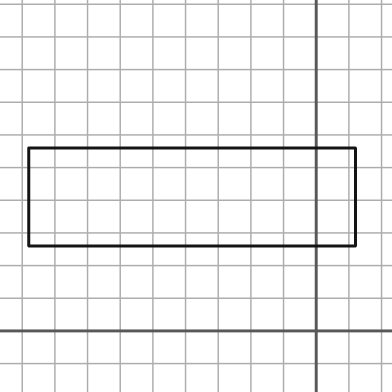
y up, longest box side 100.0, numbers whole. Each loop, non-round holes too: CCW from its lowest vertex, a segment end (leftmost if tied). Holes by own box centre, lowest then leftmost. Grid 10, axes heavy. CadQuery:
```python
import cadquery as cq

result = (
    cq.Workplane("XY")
    .moveTo(-88.0, 26.0)
    .lineTo(12.0, 26.0)
    .lineTo(12.0, 56.0)
    .lineTo(-88.0, 56.0)
    .close()
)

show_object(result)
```